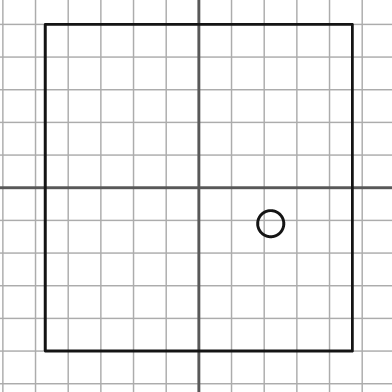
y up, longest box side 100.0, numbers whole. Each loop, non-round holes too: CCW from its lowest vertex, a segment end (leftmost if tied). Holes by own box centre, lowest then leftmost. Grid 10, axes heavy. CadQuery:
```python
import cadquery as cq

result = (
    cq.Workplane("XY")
    .moveTo(-47.0, -50.0)
    .lineTo(47.0, -50.0)
    .lineTo(47.0, 50.0)
    .lineTo(-47.0, 50.0)
    .close()
    .moveTo(22.0, -11.0)
    .circle(4.0)
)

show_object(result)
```